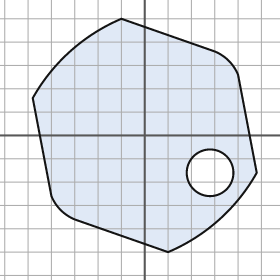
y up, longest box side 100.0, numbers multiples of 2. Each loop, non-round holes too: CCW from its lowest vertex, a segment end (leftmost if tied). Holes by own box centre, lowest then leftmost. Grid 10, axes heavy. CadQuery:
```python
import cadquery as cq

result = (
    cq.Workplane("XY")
    .moveTo(10.0, -50.0)
    .threePointArc((32.0, -36.0), (48.0, -16.0))
    .lineTo(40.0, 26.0)
    .threePointArc((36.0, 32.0), (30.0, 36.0))
    .lineTo(-10.0, 50.0)
    .threePointArc((-32.0, 36.0), (-48.0, 16.0))
    .lineTo(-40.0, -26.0)
    .threePointArc((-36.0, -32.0), (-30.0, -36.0))
    .close()
    .moveTo(28.0, -16.0)
    .circle(10.0)
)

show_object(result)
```